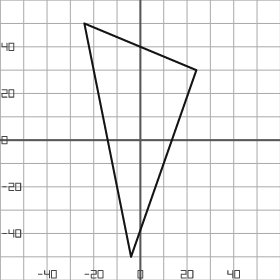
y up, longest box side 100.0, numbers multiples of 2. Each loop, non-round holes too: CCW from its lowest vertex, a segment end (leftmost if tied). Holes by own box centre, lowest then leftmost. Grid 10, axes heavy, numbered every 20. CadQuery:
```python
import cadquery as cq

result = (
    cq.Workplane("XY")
    .moveTo(-4.0, -50.0)
    .lineTo(24.0, 30.0)
    .lineTo(-24.0, 50.0)
    .close()
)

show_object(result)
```